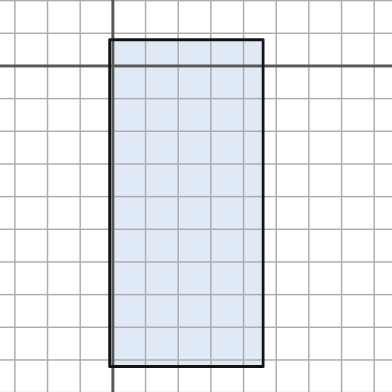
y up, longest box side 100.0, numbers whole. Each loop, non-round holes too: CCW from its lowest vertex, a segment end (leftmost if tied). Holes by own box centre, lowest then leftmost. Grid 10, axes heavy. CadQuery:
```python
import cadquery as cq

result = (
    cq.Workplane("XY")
    .moveTo(-1.0, -92.0)
    .lineTo(46.0, -92.0)
    .lineTo(46.0, 8.0)
    .lineTo(-1.0, 8.0)
    .close()
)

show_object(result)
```